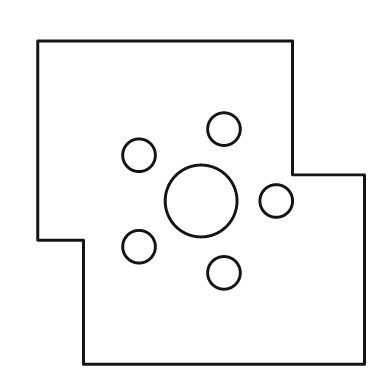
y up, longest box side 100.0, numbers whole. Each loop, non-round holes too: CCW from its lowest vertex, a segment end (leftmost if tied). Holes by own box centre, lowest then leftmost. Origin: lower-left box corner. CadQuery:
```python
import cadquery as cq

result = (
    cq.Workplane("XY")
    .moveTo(14.0, 0.0)
    .lineTo(100.0, 0.0)
    .lineTo(100.0, 58.0)
    .lineTo(78.0, 58.0)
    .lineTo(78.0, 99.0)
    .lineTo(0.0, 99.0)
    .lineTo(0.0, 38.0)
    .lineTo(14.0, 38.0)
    .close()
    .moveTo(57.0, 28.0)
    .circle(5.0)
    .moveTo(31.0, 36.0)
    .circle(5.0)
    .moveTo(50.0, 50.0)
    .circle(11.0)
    .moveTo(73.0, 50.0)
    .circle(5.0)
    .moveTo(31.0, 64.0)
    .circle(5.0)
    .moveTo(57.0, 72.0)
    .circle(5.0)
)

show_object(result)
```